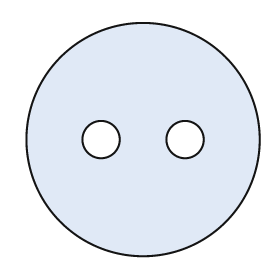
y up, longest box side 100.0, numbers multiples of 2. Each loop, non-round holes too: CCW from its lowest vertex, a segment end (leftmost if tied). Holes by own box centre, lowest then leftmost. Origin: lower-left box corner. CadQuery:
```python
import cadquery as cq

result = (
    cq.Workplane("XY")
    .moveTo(50.0, 50.0)
    .circle(50.0)
    .moveTo(32.0, 50.0)
    .circle(8.0)
    .moveTo(68.0, 50.0)
    .circle(8.0)
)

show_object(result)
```